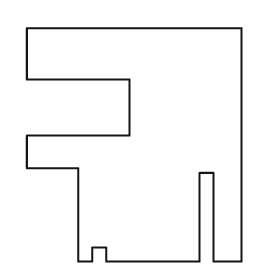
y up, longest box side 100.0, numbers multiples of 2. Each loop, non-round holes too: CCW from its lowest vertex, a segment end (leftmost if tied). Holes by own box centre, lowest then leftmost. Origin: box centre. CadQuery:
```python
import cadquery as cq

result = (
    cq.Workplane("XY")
    .moveTo(-24.0, -50.0)
    .lineTo(-18.0, -50.0)
    .lineTo(-18.0, -44.0)
    .lineTo(-12.0, -44.0)
    .lineTo(-12.0, -50.0)
    .lineTo(28.0, -50.0)
    .lineTo(28.0, -12.0)
    .lineTo(34.0, -12.0)
    .lineTo(34.0, -50.0)
    .lineTo(46.0, -50.0)
    .lineTo(46.0, 50.0)
    .lineTo(-46.0, 50.0)
    .lineTo(-46.0, 28.0)
    .lineTo(-2.0, 28.0)
    .lineTo(-2.0, 4.0)
    .lineTo(-46.0, 4.0)
    .lineTo(-46.0, -10.0)
    .lineTo(-24.0, -10.0)
    .close()
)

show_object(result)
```